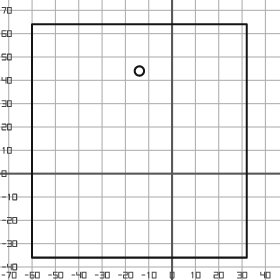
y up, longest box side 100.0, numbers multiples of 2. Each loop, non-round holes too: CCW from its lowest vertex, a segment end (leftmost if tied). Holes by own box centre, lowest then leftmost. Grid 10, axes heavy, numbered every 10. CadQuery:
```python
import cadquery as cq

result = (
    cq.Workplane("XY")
    .moveTo(-60.0, -36.0)
    .lineTo(32.0, -36.0)
    .lineTo(32.0, 64.0)
    .lineTo(-60.0, 64.0)
    .close()
    .moveTo(-14.0, 44.0)
    .circle(2.0)
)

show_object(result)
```